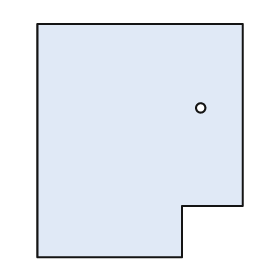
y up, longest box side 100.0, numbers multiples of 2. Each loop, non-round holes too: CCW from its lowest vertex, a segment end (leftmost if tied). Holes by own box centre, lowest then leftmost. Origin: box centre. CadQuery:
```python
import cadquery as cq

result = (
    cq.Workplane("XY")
    .moveTo(-44.0, -50.0)
    .lineTo(18.0, -50.0)
    .lineTo(18.0, -28.0)
    .lineTo(44.0, -28.0)
    .lineTo(44.0, 50.0)
    .lineTo(-44.0, 50.0)
    .close()
    .moveTo(26.0, 14.0)
    .circle(2.0)
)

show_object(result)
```